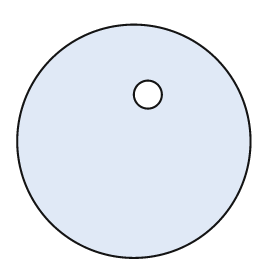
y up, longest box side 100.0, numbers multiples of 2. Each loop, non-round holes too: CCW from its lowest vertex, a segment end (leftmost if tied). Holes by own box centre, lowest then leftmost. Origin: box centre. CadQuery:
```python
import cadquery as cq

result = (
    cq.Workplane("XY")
    .moveTo(0.0, 0.0)
    .circle(50.0)
    .moveTo(6.0, 20.0)
    .circle(6.0)
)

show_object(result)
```